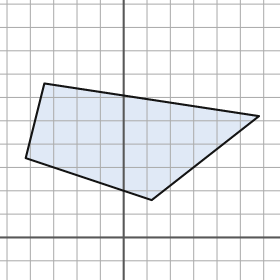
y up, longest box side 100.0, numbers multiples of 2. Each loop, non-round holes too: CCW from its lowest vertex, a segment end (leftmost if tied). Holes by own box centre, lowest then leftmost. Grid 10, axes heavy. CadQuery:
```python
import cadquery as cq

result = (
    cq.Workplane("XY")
    .moveTo(12.0, 16.0)
    .lineTo(58.0, 52.0)
    .lineTo(-34.0, 66.0)
    .lineTo(-42.0, 34.0)
    .close()
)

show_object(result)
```